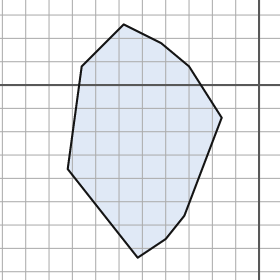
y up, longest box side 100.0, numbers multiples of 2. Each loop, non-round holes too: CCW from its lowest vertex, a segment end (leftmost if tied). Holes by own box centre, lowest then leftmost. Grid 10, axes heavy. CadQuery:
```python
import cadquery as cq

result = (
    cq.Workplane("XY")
    .moveTo(-52.0, -74.0)
    .lineTo(-40.0, -66.0)
    .lineTo(-32.0, -56.0)
    .lineTo(-16.0, -14.0)
    .lineTo(-30.0, 8.0)
    .lineTo(-42.0, 18.0)
    .lineTo(-58.0, 26.0)
    .lineTo(-76.0, 8.0)
    .lineTo(-82.0, -36.0)
    .close()
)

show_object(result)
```